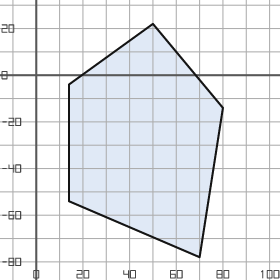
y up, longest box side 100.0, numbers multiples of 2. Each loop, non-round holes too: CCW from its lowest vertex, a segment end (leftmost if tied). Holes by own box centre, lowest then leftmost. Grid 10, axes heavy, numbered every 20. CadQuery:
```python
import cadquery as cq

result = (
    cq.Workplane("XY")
    .moveTo(70.0, -78.0)
    .lineTo(80.0, -14.0)
    .lineTo(50.0, 22.0)
    .lineTo(14.0, -4.0)
    .lineTo(14.0, -54.0)
    .close()
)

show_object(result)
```